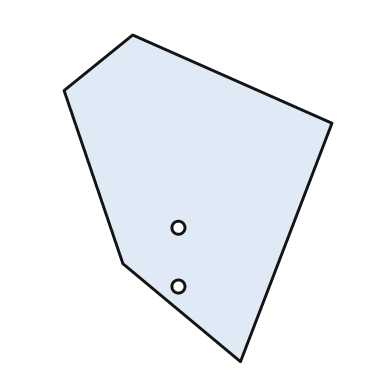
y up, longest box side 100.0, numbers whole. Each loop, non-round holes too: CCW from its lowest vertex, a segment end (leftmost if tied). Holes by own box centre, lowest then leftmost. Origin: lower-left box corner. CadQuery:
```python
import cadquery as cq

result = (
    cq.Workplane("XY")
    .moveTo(54.0, 0.0)
    .lineTo(82.0, 73.0)
    .lineTo(21.0, 100.0)
    .lineTo(0.0, 83.0)
    .lineTo(18.0, 30.0)
    .close()
    .moveTo(35.0, 23.0)
    .circle(2.0)
    .moveTo(35.0, 41.0)
    .circle(2.0)
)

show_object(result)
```